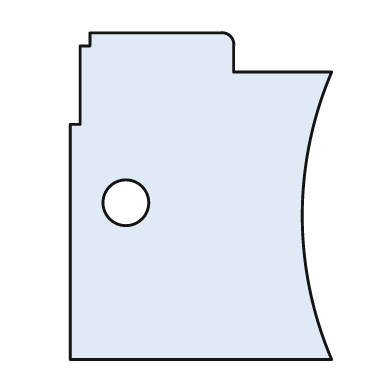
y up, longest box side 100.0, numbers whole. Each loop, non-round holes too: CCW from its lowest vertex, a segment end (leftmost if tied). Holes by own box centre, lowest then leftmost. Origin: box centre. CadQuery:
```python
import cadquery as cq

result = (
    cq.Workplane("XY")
    .moveTo(-40.0, -50.0)
    .lineTo(40.0, -50.0)
    .threePointArc((31.0, -6.0), (40.0, 38.0))
    .lineTo(10.0, 38.0)
    .lineTo(10.0, 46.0)
    .threePointArc((9.0, 49.0), (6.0, 50.0))
    .lineTo(-34.0, 50.0)
    .lineTo(-34.0, 46.0)
    .lineTo(-37.0, 46.0)
    .lineTo(-37.0, 22.0)
    .lineTo(-40.0, 22.0)
    .close()
    .moveTo(-23.0, -2.0)
    .circle(7.0)
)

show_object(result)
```